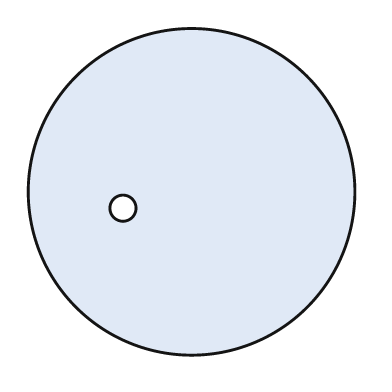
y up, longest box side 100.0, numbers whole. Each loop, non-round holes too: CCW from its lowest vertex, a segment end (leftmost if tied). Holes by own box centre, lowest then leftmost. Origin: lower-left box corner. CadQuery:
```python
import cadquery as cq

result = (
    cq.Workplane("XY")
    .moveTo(50.0, 50.0)
    .circle(50.0)
    .moveTo(29.0, 45.0)
    .circle(4.0)
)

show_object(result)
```